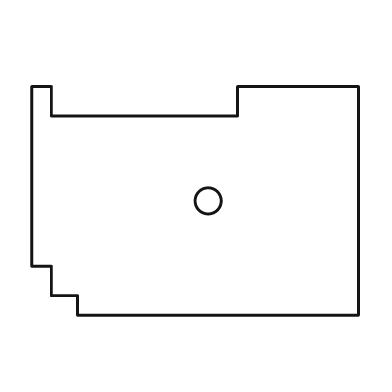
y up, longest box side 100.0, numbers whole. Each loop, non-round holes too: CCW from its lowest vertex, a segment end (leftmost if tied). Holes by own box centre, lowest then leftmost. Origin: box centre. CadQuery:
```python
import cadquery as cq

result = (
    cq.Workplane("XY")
    .moveTo(-36.0, -35.0)
    .lineTo(50.0, -35.0)
    .lineTo(50.0, 35.0)
    .lineTo(13.0, 35.0)
    .lineTo(13.0, 26.0)
    .lineTo(-44.0, 26.0)
    .lineTo(-44.0, 35.0)
    .lineTo(-50.0, 35.0)
    .lineTo(-50.0, -20.0)
    .lineTo(-44.0, -20.0)
    .lineTo(-44.0, -29.0)
    .lineTo(-36.0, -29.0)
    .close()
    .moveTo(4.0, 0.0)
    .circle(4.0)
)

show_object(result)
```